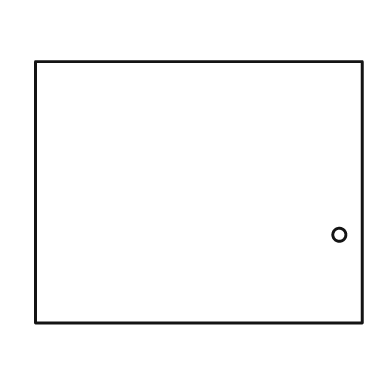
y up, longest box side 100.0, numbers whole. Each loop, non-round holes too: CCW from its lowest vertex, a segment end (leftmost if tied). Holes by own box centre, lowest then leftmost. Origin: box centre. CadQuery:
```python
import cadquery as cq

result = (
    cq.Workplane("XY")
    .moveTo(-50.0, -40.0)
    .lineTo(50.0, -40.0)
    .lineTo(50.0, 40.0)
    .lineTo(-50.0, 40.0)
    .close()
    .moveTo(43.0, -13.0)
    .circle(2.0)
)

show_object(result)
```